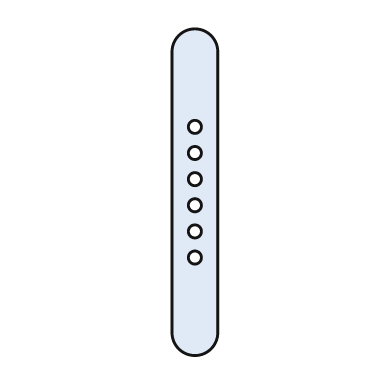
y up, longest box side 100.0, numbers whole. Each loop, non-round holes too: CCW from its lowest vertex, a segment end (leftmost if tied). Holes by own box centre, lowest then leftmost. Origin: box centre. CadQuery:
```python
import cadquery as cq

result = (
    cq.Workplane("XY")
    .moveTo(-7.0, -43.0)
    .threePointArc((0.0, -50.0), (7.0, -43.0))
    .lineTo(7.0, 43.0)
    .threePointArc((0.0, 50.0), (-7.0, 43.0))
    .close()
    .moveTo(0.0, -20.0)
    .circle(2.0)
    .moveTo(0.0, -12.0)
    .circle(2.0)
    .moveTo(0.0, -4.0)
    .circle(2.0)
    .moveTo(0.0, 4.0)
    .circle(2.0)
    .moveTo(0.0, 12.0)
    .circle(2.0)
    .moveTo(0.0, 20.0)
    .circle(2.0)
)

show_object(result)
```